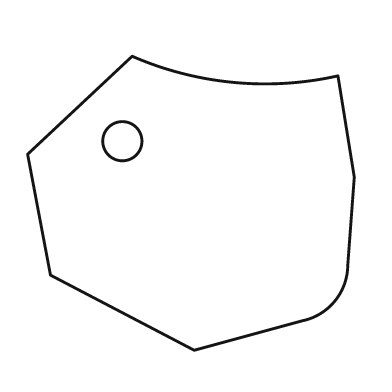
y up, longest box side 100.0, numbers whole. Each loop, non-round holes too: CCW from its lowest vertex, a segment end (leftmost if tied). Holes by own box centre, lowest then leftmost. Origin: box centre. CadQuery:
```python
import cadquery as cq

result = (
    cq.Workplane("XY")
    .moveTo(1.0, -45.0)
    .lineTo(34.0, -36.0)
    .threePointArc((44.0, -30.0), (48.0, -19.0))
    .lineTo(50.0, 8.0)
    .lineTo(45.0, 39.0)
    .threePointArc((13.0, 37.0), (-18.0, 45.0))
    .lineTo(-50.0, 15.0)
    .lineTo(-43.0, -22.0)
    .close()
    .moveTo(-21.0, 19.0)
    .circle(6.0)
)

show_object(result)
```